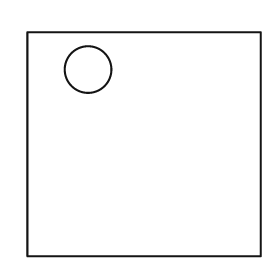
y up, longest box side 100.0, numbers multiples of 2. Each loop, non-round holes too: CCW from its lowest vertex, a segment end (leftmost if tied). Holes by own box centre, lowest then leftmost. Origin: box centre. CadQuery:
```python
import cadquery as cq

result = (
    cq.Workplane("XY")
    .moveTo(-50.0, -48.0)
    .lineTo(50.0, -48.0)
    .lineTo(50.0, 48.0)
    .lineTo(-50.0, 48.0)
    .close()
    .moveTo(-24.0, 32.0)
    .circle(10.0)
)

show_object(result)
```